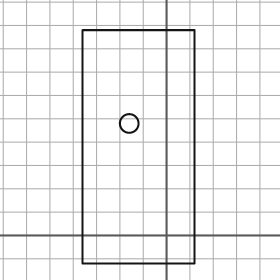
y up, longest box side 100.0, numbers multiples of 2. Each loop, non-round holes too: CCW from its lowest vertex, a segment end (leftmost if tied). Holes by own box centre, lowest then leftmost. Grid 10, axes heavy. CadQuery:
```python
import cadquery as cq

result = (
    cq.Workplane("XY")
    .moveTo(-36.0, -12.0)
    .lineTo(12.0, -12.0)
    .lineTo(12.0, 88.0)
    .lineTo(-36.0, 88.0)
    .close()
    .moveTo(-16.0, 48.0)
    .circle(4.0)
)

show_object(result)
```